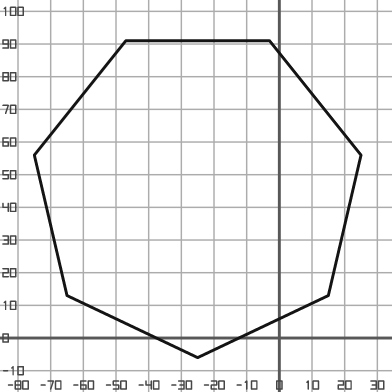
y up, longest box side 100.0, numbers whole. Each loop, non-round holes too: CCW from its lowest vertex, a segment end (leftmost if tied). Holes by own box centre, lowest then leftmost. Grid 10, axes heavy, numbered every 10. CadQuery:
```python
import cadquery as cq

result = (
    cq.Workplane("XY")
    .moveTo(-25.0, -6.0)
    .lineTo(15.0, 13.0)
    .lineTo(25.0, 56.0)
    .lineTo(-3.0, 91.0)
    .lineTo(-47.0, 91.0)
    .lineTo(-75.0, 56.0)
    .lineTo(-65.0, 13.0)
    .close()
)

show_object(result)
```